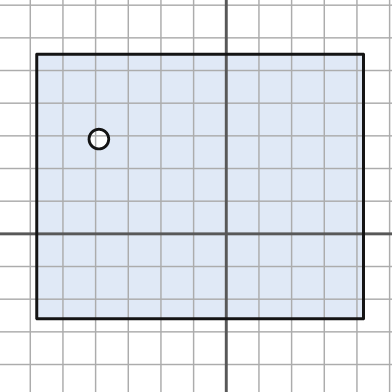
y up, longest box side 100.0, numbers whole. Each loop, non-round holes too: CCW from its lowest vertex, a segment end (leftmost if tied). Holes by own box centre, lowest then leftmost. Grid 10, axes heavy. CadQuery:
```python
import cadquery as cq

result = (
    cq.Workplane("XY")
    .moveTo(-58.0, -26.0)
    .lineTo(42.0, -26.0)
    .lineTo(42.0, 55.0)
    .lineTo(-58.0, 55.0)
    .close()
    .moveTo(-39.0, 29.0)
    .circle(3.0)
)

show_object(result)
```